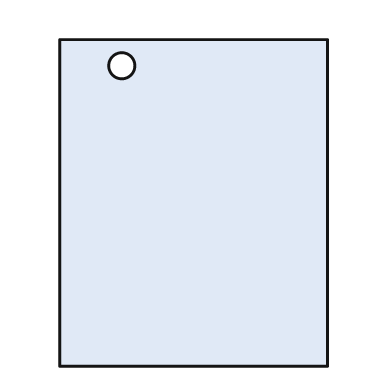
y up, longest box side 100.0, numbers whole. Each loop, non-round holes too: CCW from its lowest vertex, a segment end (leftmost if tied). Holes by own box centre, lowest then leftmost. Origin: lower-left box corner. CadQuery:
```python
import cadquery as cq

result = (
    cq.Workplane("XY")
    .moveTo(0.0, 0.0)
    .lineTo(82.0, 0.0)
    .lineTo(82.0, 100.0)
    .lineTo(0.0, 100.0)
    .close()
    .moveTo(19.0, 92.0)
    .circle(4.0)
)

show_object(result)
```